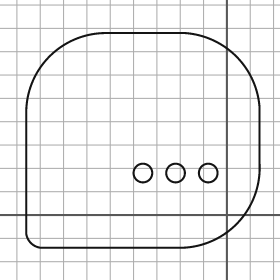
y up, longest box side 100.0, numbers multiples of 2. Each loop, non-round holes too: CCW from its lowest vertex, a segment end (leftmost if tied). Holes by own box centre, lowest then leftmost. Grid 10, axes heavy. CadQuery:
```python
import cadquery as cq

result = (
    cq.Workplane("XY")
    .moveTo(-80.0, -14.0)
    .lineTo(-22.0, -14.0)
    .threePointArc((4.0, -4.0), (14.0, 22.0))
    .lineTo(14.0, 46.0)
    .threePointArc((4.0, 68.0), (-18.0, 78.0))
    .lineTo(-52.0, 78.0)
    .threePointArc((-76.0, 68.0), (-86.0, 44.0))
    .lineTo(-86.0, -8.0)
    .threePointArc((-84.0, -12.0), (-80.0, -14.0))
    .close()
    .moveTo(-36.0, 18.0)
    .circle(4.0)
    .moveTo(-22.0, 18.0)
    .circle(4.0)
    .moveTo(-8.0, 18.0)
    .circle(4.0)
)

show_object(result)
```